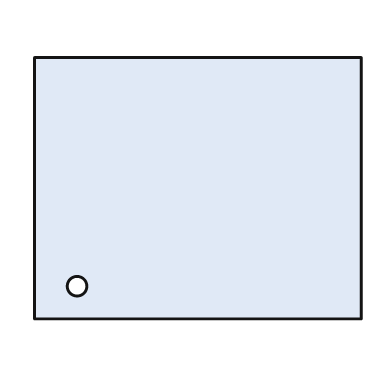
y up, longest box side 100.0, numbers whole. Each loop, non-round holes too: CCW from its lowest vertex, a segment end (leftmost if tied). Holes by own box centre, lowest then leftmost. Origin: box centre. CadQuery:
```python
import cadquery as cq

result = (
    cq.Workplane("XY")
    .moveTo(-50.0, -40.0)
    .lineTo(50.0, -40.0)
    .lineTo(50.0, 40.0)
    .lineTo(-50.0, 40.0)
    .close()
    .moveTo(-37.0, -30.0)
    .circle(3.0)
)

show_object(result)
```